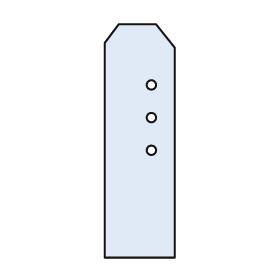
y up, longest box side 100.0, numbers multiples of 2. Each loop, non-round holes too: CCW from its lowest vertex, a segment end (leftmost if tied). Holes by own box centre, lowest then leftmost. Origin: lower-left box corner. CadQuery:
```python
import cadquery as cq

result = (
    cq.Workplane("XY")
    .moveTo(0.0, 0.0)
    .lineTo(30.0, 0.0)
    .lineTo(30.0, 90.0)
    .lineTo(22.0, 100.0)
    .lineTo(6.0, 100.0)
    .lineTo(0.0, 92.0)
    .close()
    .moveTo(20.0, 46.0)
    .circle(2.0)
    .moveTo(20.0, 60.0)
    .circle(2.0)
    .moveTo(20.0, 74.0)
    .circle(2.0)
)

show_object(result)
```